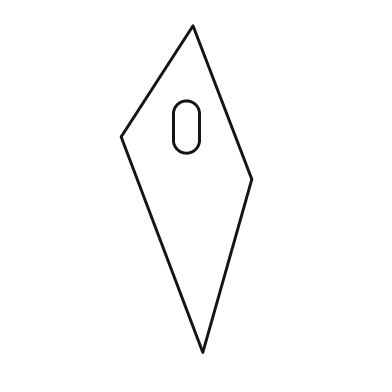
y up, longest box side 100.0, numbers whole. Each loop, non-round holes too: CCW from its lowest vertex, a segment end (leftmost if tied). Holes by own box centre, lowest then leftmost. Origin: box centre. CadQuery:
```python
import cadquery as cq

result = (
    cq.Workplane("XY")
    .moveTo(5.0, -50.0)
    .lineTo(20.0, 3.0)
    .lineTo(2.0, 50.0)
    .lineTo(-20.0, 16.0)
    .close()
    .moveTo(-4.0, 15.0)
    .threePointArc((0.0, 11.0), (4.0, 15.0))
    .lineTo(4.0, 23.0)
    .threePointArc((0.0, 27.0), (-4.0, 23.0))
    .close()
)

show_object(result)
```